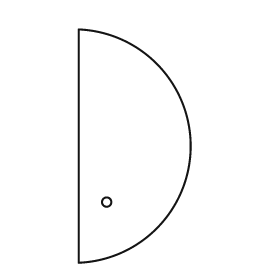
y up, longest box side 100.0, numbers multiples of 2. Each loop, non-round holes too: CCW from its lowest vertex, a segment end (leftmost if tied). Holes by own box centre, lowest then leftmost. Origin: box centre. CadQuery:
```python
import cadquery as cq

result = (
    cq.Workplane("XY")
    .moveTo(-24.0, -50.0)
    .threePointArc((24.0, 0.0), (-24.0, 50.0))
    .close()
    .moveTo(-12.0, -24.0)
    .circle(2.0)
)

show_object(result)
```